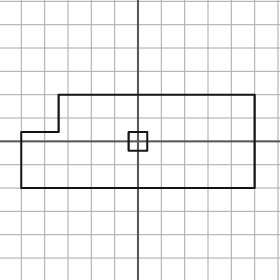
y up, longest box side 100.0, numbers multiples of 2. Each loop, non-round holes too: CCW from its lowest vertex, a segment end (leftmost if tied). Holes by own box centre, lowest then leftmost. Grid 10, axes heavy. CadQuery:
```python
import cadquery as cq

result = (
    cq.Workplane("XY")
    .moveTo(-50.0, -20.0)
    .lineTo(50.0, -20.0)
    .lineTo(50.0, 20.0)
    .lineTo(-34.0, 20.0)
    .lineTo(-34.0, 4.0)
    .lineTo(-50.0, 4.0)
    .close()
    .moveTo(-4.0, -4.0)
    .lineTo(4.0, -4.0)
    .lineTo(4.0, 4.0)
    .lineTo(-4.0, 4.0)
    .close()
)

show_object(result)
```